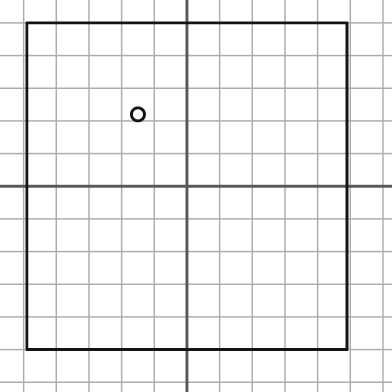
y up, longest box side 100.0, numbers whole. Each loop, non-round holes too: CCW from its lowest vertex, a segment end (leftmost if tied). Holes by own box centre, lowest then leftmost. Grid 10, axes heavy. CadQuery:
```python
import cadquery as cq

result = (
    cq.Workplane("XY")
    .moveTo(-49.0, -50.0)
    .lineTo(49.0, -50.0)
    .lineTo(49.0, 50.0)
    .lineTo(-49.0, 50.0)
    .close()
    .moveTo(-15.0, 22.0)
    .circle(2.0)
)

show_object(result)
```